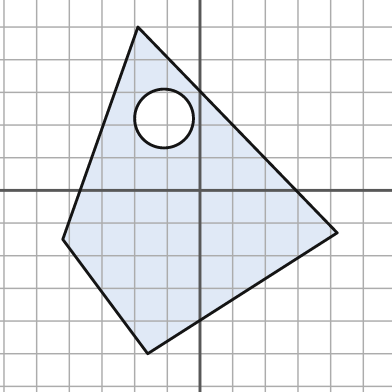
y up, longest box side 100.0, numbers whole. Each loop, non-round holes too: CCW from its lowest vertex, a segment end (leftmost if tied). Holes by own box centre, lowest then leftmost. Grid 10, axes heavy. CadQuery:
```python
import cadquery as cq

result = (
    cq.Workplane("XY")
    .moveTo(-16.0, -50.0)
    .lineTo(42.0, -13.0)
    .lineTo(-19.0, 50.0)
    .lineTo(-42.0, -15.0)
    .close()
    .moveTo(-11.0, 22.0)
    .circle(9.0)
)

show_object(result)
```